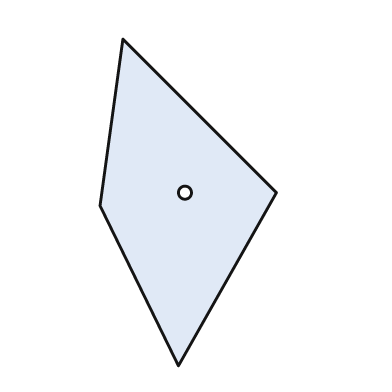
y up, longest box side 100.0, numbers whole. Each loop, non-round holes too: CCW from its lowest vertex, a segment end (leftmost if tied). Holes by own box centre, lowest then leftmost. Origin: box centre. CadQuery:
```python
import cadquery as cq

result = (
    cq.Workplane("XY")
    .moveTo(-3.0, -50.0)
    .lineTo(27.0, 3.0)
    .lineTo(-20.0, 50.0)
    .lineTo(-27.0, -1.0)
    .close()
    .moveTo(-1.0, 3.0)
    .circle(2.0)
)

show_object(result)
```